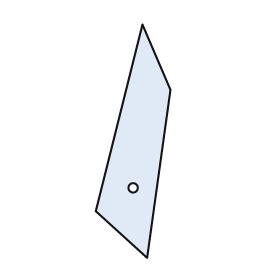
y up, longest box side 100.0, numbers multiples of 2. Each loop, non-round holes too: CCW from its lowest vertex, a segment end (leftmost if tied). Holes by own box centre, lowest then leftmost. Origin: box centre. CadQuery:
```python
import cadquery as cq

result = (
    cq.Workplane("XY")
    .moveTo(6.0, -50.0)
    .lineTo(16.0, 22.0)
    .lineTo(4.0, 50.0)
    .lineTo(-16.0, -30.0)
    .close()
    .moveTo(0.0, -20.0)
    .circle(2.0)
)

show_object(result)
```